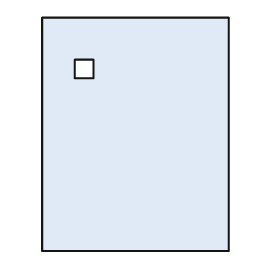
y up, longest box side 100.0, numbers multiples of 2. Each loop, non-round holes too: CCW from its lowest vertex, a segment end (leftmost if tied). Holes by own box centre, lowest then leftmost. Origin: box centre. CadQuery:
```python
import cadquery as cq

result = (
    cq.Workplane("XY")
    .moveTo(-40.0, -50.0)
    .lineTo(40.0, -50.0)
    .lineTo(40.0, 50.0)
    .lineTo(-40.0, 50.0)
    .close()
    .moveTo(-26.0, 24.0)
    .lineTo(-18.0, 24.0)
    .lineTo(-18.0, 32.0)
    .lineTo(-26.0, 32.0)
    .close()
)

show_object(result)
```